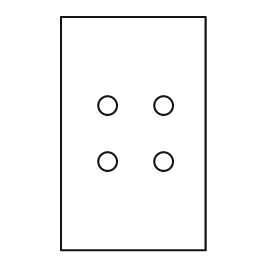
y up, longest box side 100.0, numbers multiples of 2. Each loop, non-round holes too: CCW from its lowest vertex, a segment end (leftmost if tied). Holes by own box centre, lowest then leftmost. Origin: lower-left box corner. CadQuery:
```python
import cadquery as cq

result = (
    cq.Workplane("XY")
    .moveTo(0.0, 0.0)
    .lineTo(62.0, 0.0)
    .lineTo(62.0, 100.0)
    .lineTo(0.0, 100.0)
    .close()
    .moveTo(20.0, 38.0)
    .circle(4.0)
    .moveTo(44.0, 38.0)
    .circle(4.0)
    .moveTo(20.0, 62.0)
    .circle(4.0)
    .moveTo(44.0, 62.0)
    .circle(4.0)
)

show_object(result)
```